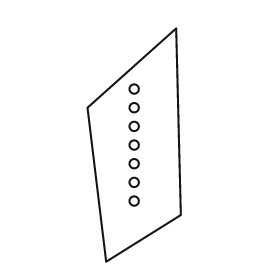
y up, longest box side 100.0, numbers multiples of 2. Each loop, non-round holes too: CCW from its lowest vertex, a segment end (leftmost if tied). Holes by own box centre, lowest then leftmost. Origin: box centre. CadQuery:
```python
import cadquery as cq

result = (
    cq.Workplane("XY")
    .moveTo(-12.0, -50.0)
    .lineTo(20.0, -30.0)
    .lineTo(18.0, 50.0)
    .lineTo(-20.0, 16.0)
    .close()
    .moveTo(0.0, -24.0)
    .circle(2.0)
    .moveTo(0.0, -16.0)
    .circle(2.0)
    .moveTo(0.0, -8.0)
    .circle(2.0)
    .moveTo(0.0, 0.0)
    .circle(2.0)
    .moveTo(0.0, 8.0)
    .circle(2.0)
    .moveTo(0.0, 16.0)
    .circle(2.0)
    .moveTo(0.0, 24.0)
    .circle(2.0)
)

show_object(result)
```